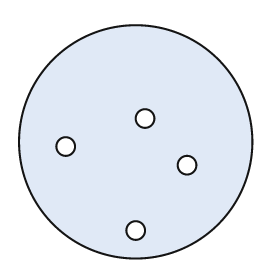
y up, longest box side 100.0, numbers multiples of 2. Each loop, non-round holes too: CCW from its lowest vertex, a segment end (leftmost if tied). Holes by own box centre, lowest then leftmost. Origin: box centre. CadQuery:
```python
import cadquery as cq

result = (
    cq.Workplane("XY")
    .moveTo(0.0, 0.0)
    .circle(50.0)
    .moveTo(0.0, -38.0)
    .circle(4.0)
    .moveTo(22.0, -10.0)
    .circle(4.0)
    .moveTo(-30.0, -2.0)
    .circle(4.0)
    .moveTo(4.0, 10.0)
    .circle(4.0)
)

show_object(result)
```